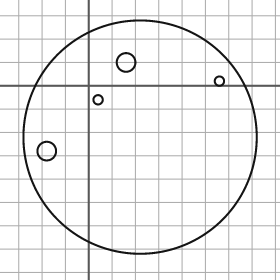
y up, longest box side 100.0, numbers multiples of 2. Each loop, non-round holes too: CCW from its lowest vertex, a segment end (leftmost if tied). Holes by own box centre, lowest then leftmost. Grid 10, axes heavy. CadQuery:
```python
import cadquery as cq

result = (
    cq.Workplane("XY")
    .moveTo(22.0, -22.0)
    .circle(50.0)
    .moveTo(-18.0, -28.0)
    .circle(4.0)
    .moveTo(4.0, -6.0)
    .circle(2.0)
    .moveTo(56.0, 2.0)
    .circle(2.0)
    .moveTo(16.0, 10.0)
    .circle(4.0)
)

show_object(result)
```